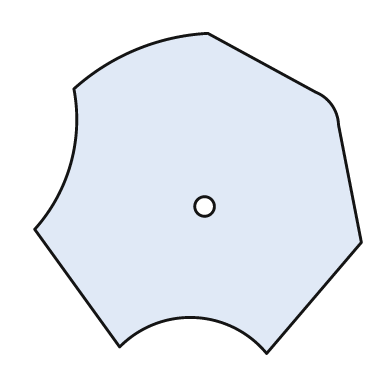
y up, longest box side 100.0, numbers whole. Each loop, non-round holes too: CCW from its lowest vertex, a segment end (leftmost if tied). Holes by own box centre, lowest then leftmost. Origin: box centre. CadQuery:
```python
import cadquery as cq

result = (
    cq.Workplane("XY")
    .moveTo(21.0, -49.0)
    .lineTo(50.0, -15.0)
    .lineTo(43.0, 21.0)
    .threePointArc((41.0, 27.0), (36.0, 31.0))
    .lineTo(3.0, 49.0)
    .threePointArc((-19.0, 44.0), (-38.0, 32.0))
    .threePointArc((-39.0, 9.0), (-50.0, -11.0))
    .lineTo(-24.0, -47.0)
    .threePointArc((-1.0, -38.0), (21.0, -49.0))
    .close()
    .moveTo(2.0, -4.0)
    .circle(3.0)
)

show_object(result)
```